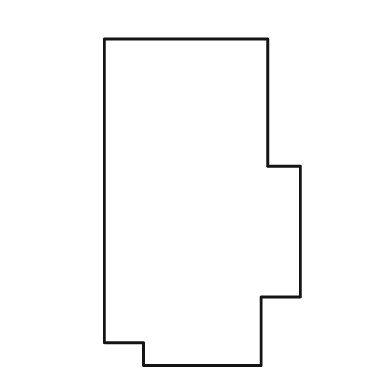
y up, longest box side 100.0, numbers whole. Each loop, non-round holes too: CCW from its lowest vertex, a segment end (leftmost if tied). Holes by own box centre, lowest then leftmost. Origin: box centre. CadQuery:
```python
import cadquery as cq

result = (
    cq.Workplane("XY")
    .moveTo(-18.0, -50.0)
    .lineTo(18.0, -50.0)
    .lineTo(18.0, -29.0)
    .lineTo(30.0, -29.0)
    .lineTo(30.0, 11.0)
    .lineTo(20.0, 11.0)
    .lineTo(20.0, 50.0)
    .lineTo(-30.0, 50.0)
    .lineTo(-30.0, -43.0)
    .lineTo(-18.0, -43.0)
    .close()
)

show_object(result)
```